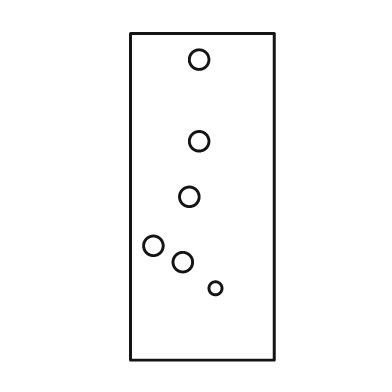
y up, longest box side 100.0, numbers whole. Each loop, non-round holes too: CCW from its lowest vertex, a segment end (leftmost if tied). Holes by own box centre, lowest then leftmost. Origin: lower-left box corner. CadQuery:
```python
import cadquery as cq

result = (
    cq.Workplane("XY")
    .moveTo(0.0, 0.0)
    .lineTo(44.0, 0.0)
    .lineTo(44.0, 100.0)
    .lineTo(0.0, 100.0)
    .close()
    .moveTo(26.0, 22.0)
    .circle(2.0)
    .moveTo(16.0, 30.0)
    .circle(3.0)
    .moveTo(7.0, 35.0)
    .circle(3.0)
    .moveTo(18.0, 50.0)
    .circle(3.0)
    .moveTo(21.0, 67.0)
    .circle(3.0)
    .moveTo(21.0, 92.0)
    .circle(3.0)
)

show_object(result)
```